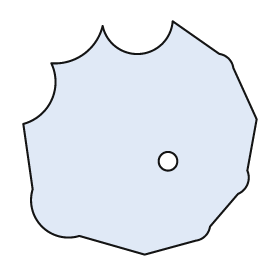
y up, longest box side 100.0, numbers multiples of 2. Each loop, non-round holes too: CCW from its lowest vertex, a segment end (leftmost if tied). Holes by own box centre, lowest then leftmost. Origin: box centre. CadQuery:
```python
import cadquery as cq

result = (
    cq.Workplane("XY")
    .moveTo(2.0, -50.0)
    .lineTo(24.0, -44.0)
    .threePointArc((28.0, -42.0), (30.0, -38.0))
    .lineTo(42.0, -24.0)
    .threePointArc((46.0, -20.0), (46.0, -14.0))
    .lineTo(50.0, 8.0)
    .lineTo(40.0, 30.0)
    .threePointArc((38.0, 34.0), (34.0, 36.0))
    .lineTo(14.0, 50.0)
    .threePointArc((0.0, 36.0), (-16.0, 48.0))
    .threePointArc((-24.0, 36.0), (-38.0, 32.0))
    .threePointArc((-38.0, 16.0), (-50.0, 6.0))
    .lineTo(-46.0, -22.0)
    .threePointArc((-42.0, -38.0), (-26.0, -42.0))
    .close()
    .moveTo(12.0, -10.0)
    .circle(4.0)
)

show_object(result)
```